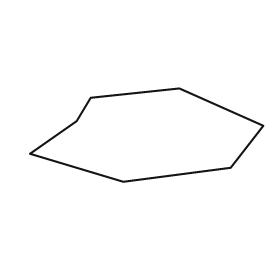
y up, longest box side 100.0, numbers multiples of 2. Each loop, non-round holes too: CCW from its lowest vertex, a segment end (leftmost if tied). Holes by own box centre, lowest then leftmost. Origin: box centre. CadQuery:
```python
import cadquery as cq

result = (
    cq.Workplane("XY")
    .moveTo(-10.0, -20.0)
    .lineTo(36.0, -14.0)
    .lineTo(50.0, 4.0)
    .lineTo(14.0, 20.0)
    .lineTo(-24.0, 16.0)
    .lineTo(-30.0, 6.0)
    .lineTo(-50.0, -8.0)
    .close()
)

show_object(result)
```